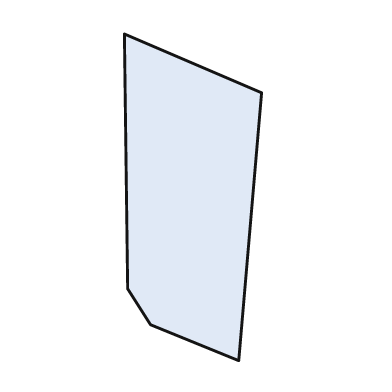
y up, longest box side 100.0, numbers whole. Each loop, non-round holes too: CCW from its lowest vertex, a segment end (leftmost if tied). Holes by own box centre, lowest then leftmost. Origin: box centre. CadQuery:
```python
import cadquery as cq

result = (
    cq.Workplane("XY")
    .moveTo(14.0, -50.0)
    .lineTo(21.0, 32.0)
    .lineTo(-21.0, 50.0)
    .lineTo(-20.0, -28.0)
    .lineTo(-13.0, -39.0)
    .close()
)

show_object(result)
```